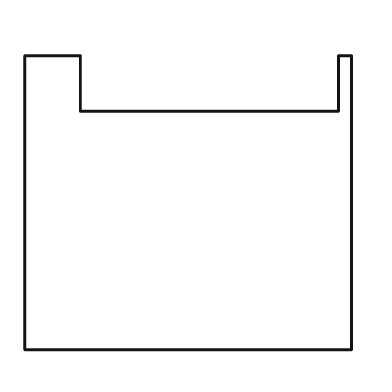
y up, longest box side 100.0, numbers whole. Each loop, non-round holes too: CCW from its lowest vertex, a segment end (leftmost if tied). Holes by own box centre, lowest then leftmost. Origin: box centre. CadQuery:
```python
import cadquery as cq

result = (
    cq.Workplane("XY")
    .moveTo(-50.0, -45.0)
    .lineTo(50.0, -45.0)
    .lineTo(50.0, 45.0)
    .lineTo(46.0, 45.0)
    .lineTo(46.0, 28.0)
    .lineTo(-33.0, 28.0)
    .lineTo(-33.0, 45.0)
    .lineTo(-50.0, 45.0)
    .close()
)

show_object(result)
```